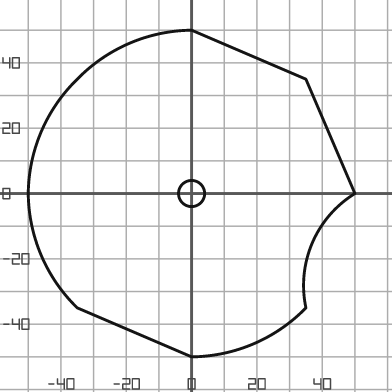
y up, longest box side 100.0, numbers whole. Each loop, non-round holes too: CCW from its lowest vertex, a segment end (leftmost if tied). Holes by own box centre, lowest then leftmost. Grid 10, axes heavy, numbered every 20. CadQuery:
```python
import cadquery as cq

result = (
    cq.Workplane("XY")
    .moveTo(0.0, -50.0)
    .threePointArc((19.0, -46.0), (35.0, -35.0))
    .threePointArc((37.0, -15.0), (50.0, 0.0))
    .lineTo(35.0, 35.0)
    .lineTo(0.0, 50.0)
    .threePointArc((-19.0, 46.0), (-35.0, 35.0))
    .threePointArc((-46.0, 19.0), (-50.0, 0.0))
    .threePointArc((-46.0, -19.0), (-35.0, -35.0))
    .close()
    .moveTo(0.0, 0.0)
    .circle(4.0)
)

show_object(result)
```